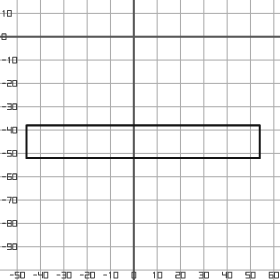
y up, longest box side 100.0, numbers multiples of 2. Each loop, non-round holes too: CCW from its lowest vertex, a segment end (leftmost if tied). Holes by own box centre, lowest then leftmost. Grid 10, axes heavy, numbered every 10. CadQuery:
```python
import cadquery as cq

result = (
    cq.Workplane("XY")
    .moveTo(-46.0, -52.0)
    .lineTo(54.0, -52.0)
    .lineTo(54.0, -38.0)
    .lineTo(-46.0, -38.0)
    .close()
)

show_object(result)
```